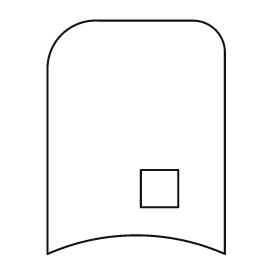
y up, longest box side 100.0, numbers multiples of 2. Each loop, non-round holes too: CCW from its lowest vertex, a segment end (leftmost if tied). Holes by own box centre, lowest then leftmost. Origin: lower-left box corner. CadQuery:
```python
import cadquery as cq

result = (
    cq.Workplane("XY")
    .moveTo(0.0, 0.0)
    .threePointArc((38.0, 8.0), (76.0, 0.0))
    .lineTo(76.0, 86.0)
    .threePointArc((72.0, 96.0), (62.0, 100.0))
    .lineTo(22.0, 100.0)
    .threePointArc((6.0, 94.0), (0.0, 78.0))
    .close()
    .moveTo(40.0, 20.0)
    .lineTo(56.0, 20.0)
    .lineTo(56.0, 36.0)
    .lineTo(40.0, 36.0)
    .close()
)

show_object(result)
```